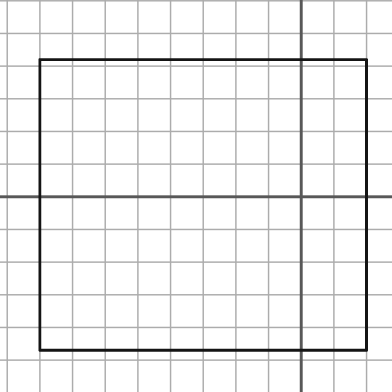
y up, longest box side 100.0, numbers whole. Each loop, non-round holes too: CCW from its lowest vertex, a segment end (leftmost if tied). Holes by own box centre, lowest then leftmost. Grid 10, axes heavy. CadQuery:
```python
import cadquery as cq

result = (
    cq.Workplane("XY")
    .moveTo(-80.0, -47.0)
    .lineTo(20.0, -47.0)
    .lineTo(20.0, 42.0)
    .lineTo(-80.0, 42.0)
    .close()
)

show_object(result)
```